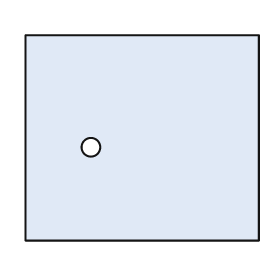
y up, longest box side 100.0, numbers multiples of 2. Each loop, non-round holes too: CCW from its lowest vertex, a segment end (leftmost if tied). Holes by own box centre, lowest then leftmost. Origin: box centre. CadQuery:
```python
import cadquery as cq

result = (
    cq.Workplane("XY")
    .moveTo(-50.0, -44.0)
    .lineTo(50.0, -44.0)
    .lineTo(50.0, 44.0)
    .lineTo(-50.0, 44.0)
    .close()
    .moveTo(-22.0, -4.0)
    .circle(4.0)
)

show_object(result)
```